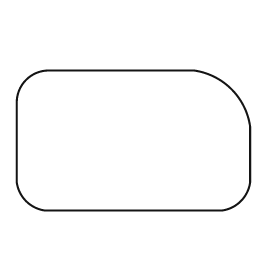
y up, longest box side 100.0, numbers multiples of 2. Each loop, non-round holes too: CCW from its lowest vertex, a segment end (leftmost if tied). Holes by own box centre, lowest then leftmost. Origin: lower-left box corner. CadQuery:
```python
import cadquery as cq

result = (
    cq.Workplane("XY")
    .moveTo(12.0, 0.0)
    .lineTo(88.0, 0.0)
    .threePointArc((96.0, 4.0), (100.0, 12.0))
    .lineTo(100.0, 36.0)
    .threePointArc((92.0, 52.0), (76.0, 60.0))
    .lineTo(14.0, 60.0)
    .threePointArc((4.0, 56.0), (0.0, 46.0))
    .lineTo(0.0, 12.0)
    .threePointArc((4.0, 4.0), (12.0, 0.0))
    .close()
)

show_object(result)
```